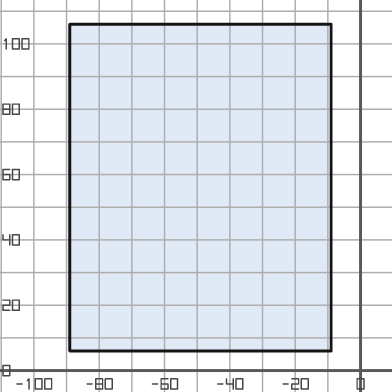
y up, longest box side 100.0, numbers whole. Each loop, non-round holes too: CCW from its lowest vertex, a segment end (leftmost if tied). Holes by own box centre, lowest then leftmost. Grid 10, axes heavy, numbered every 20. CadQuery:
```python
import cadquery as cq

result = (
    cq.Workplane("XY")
    .moveTo(-89.0, 6.0)
    .lineTo(-9.0, 6.0)
    .lineTo(-9.0, 106.0)
    .lineTo(-89.0, 106.0)
    .close()
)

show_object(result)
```